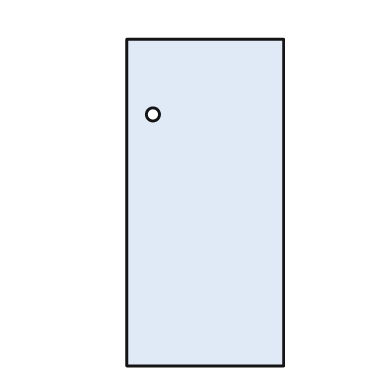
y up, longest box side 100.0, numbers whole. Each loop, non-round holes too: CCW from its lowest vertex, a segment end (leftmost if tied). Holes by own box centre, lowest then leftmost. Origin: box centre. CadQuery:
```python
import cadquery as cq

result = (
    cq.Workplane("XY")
    .moveTo(-24.0, -50.0)
    .lineTo(24.0, -50.0)
    .lineTo(24.0, 50.0)
    .lineTo(-24.0, 50.0)
    .close()
    .moveTo(-16.0, 27.0)
    .circle(2.0)
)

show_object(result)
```